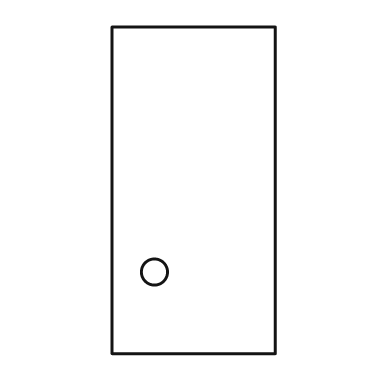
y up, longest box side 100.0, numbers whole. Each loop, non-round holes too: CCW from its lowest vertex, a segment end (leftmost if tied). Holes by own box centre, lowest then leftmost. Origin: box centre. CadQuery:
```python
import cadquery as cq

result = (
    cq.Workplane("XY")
    .moveTo(-25.0, -50.0)
    .lineTo(25.0, -50.0)
    .lineTo(25.0, 50.0)
    .lineTo(-25.0, 50.0)
    .close()
    .moveTo(-12.0, -25.0)
    .circle(4.0)
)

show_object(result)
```